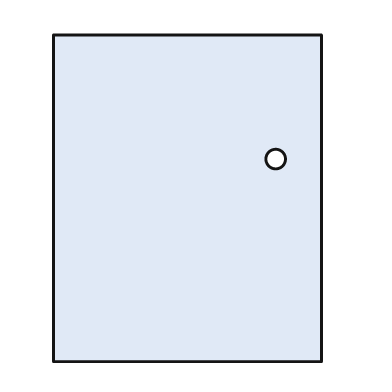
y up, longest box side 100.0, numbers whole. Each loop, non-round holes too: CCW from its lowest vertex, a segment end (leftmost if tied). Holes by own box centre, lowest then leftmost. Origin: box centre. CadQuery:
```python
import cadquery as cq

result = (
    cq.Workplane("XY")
    .moveTo(-41.0, -50.0)
    .lineTo(41.0, -50.0)
    .lineTo(41.0, 50.0)
    .lineTo(-41.0, 50.0)
    .close()
    .moveTo(27.0, 12.0)
    .circle(3.0)
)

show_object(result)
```